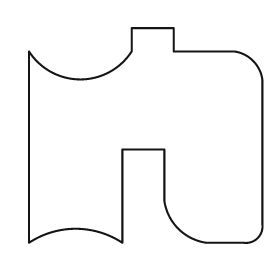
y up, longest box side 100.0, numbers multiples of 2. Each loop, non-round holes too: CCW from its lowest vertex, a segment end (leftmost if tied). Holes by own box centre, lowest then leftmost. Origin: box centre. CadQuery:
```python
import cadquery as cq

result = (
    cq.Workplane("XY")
    .moveTo(-50.0, -46.0)
    .threePointArc((-30.0, -40.0), (-10.0, -46.0))
    .lineTo(-10.0, -6.0)
    .lineTo(8.0, -6.0)
    .lineTo(8.0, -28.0)
    .threePointArc((14.0, -40.0), (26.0, -46.0))
    .lineTo(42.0, -46.0)
    .threePointArc((48.0, -44.0), (50.0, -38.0))
    .lineTo(50.0, 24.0)
    .threePointArc((46.0, 32.0), (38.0, 36.0))
    .lineTo(12.0, 36.0)
    .lineTo(12.0, 46.0)
    .lineTo(-6.0, 46.0)
    .lineTo(-6.0, 36.0)
    .threePointArc((-28.0, 24.0), (-50.0, 36.0))
    .close()
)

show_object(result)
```